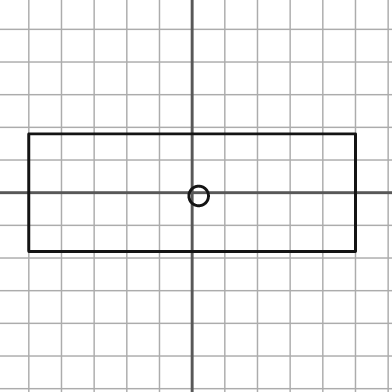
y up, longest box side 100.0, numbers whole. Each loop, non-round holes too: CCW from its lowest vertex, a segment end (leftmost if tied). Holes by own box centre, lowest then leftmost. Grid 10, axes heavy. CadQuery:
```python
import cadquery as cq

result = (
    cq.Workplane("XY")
    .moveTo(-50.0, -18.0)
    .lineTo(50.0, -18.0)
    .lineTo(50.0, 18.0)
    .lineTo(-50.0, 18.0)
    .close()
    .moveTo(2.0, -1.0)
    .circle(3.0)
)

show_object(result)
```